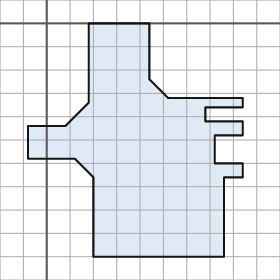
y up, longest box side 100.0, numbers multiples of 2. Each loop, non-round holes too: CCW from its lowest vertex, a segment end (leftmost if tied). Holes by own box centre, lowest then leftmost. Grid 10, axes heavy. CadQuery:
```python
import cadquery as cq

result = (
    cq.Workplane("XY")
    .moveTo(20.0, -100.0)
    .lineTo(76.0, -100.0)
    .lineTo(76.0, -66.0)
    .lineTo(84.0, -66.0)
    .lineTo(84.0, -60.0)
    .lineTo(72.0, -60.0)
    .lineTo(72.0, -48.0)
    .lineTo(84.0, -48.0)
    .lineTo(84.0, -42.0)
    .lineTo(68.0, -42.0)
    .lineTo(68.0, -36.0)
    .lineTo(84.0, -36.0)
    .lineTo(84.0, -32.0)
    .lineTo(52.0, -32.0)
    .lineTo(44.0, -24.0)
    .lineTo(44.0, 0.0)
    .lineTo(18.0, 0.0)
    .lineTo(18.0, -34.0)
    .lineTo(8.0, -44.0)
    .lineTo(-8.0, -44.0)
    .lineTo(-8.0, -58.0)
    .lineTo(12.0, -58.0)
    .lineTo(20.0, -66.0)
    .close()
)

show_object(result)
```